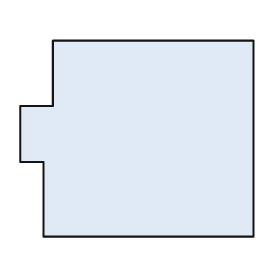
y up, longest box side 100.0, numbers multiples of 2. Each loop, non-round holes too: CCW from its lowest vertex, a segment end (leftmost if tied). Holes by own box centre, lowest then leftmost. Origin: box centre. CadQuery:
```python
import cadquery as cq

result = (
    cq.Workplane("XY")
    .moveTo(-40.0, -42.0)
    .lineTo(50.0, -42.0)
    .lineTo(50.0, 42.0)
    .lineTo(-36.0, 42.0)
    .lineTo(-36.0, 14.0)
    .lineTo(-50.0, 14.0)
    .lineTo(-50.0, -10.0)
    .lineTo(-40.0, -10.0)
    .close()
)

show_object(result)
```